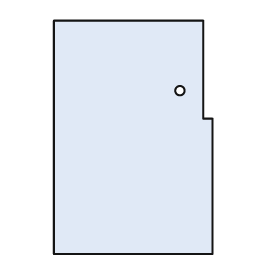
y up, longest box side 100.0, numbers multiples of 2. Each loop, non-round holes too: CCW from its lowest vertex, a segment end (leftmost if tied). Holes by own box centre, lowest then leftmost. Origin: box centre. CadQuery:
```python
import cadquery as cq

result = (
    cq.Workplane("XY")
    .moveTo(-34.0, -50.0)
    .lineTo(34.0, -50.0)
    .lineTo(34.0, 8.0)
    .lineTo(30.0, 8.0)
    .lineTo(30.0, 50.0)
    .lineTo(-34.0, 50.0)
    .close()
    .moveTo(20.0, 20.0)
    .circle(2.0)
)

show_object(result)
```